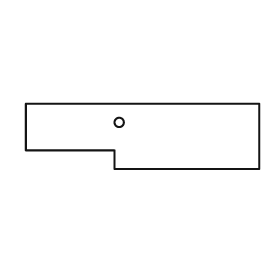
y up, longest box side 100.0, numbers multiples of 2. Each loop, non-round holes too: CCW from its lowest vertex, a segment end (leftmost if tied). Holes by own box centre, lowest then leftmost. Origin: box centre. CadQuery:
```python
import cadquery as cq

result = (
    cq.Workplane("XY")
    .moveTo(-12.0, -14.0)
    .lineTo(50.0, -14.0)
    .lineTo(50.0, 14.0)
    .lineTo(-50.0, 14.0)
    .lineTo(-50.0, -6.0)
    .lineTo(-12.0, -6.0)
    .close()
    .moveTo(-10.0, 6.0)
    .circle(2.0)
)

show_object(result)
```